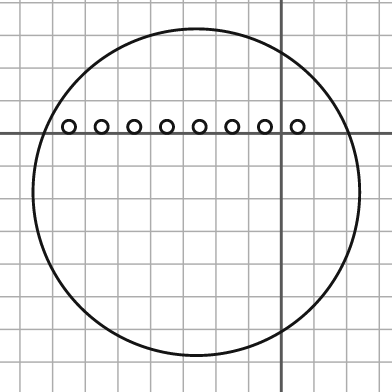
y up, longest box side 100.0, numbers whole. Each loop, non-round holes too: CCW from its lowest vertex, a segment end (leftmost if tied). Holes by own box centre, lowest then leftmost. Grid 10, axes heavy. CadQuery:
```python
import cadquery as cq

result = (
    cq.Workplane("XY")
    .moveTo(-26.0, -18.0)
    .circle(50.0)
    .moveTo(-65.0, 2.0)
    .circle(2.0)
    .moveTo(-55.0, 2.0)
    .circle(2.0)
    .moveTo(-45.0, 2.0)
    .circle(2.0)
    .moveTo(-35.0, 2.0)
    .circle(2.0)
    .moveTo(-25.0, 2.0)
    .circle(2.0)
    .moveTo(-15.0, 2.0)
    .circle(2.0)
    .moveTo(-5.0, 2.0)
    .circle(2.0)
    .moveTo(5.0, 2.0)
    .circle(2.0)
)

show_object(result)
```